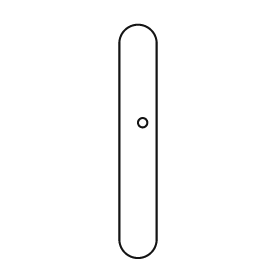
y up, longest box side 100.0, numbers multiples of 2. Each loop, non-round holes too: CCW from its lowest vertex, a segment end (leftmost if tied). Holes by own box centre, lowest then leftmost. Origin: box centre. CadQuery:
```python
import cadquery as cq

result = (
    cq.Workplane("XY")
    .moveTo(-8.0, -42.0)
    .threePointArc((0.0, -50.0), (8.0, -42.0))
    .lineTo(8.0, 42.0)
    .threePointArc((0.0, 50.0), (-8.0, 42.0))
    .close()
    .moveTo(2.0, 8.0)
    .circle(2.0)
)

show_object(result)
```